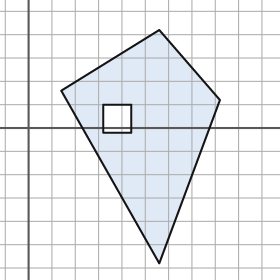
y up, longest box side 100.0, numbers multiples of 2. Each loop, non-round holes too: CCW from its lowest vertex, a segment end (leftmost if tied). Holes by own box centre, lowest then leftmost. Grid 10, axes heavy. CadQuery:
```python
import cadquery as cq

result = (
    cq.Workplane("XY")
    .moveTo(56.0, -58.0)
    .lineTo(82.0, 12.0)
    .lineTo(56.0, 42.0)
    .lineTo(14.0, 16.0)
    .close()
    .moveTo(32.0, -2.0)
    .lineTo(44.0, -2.0)
    .lineTo(44.0, 10.0)
    .lineTo(32.0, 10.0)
    .close()
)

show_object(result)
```